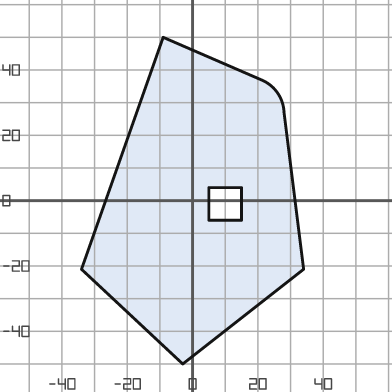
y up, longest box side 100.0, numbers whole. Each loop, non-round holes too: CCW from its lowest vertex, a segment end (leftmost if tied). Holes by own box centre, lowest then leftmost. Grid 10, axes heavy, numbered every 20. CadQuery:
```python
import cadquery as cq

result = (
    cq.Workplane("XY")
    .moveTo(-3.0, -50.0)
    .lineTo(34.0, -21.0)
    .lineTo(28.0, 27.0)
    .threePointArc((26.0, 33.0), (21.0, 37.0))
    .lineTo(-9.0, 50.0)
    .lineTo(-34.0, -21.0)
    .close()
    .moveTo(5.0, -6.0)
    .lineTo(15.0, -6.0)
    .lineTo(15.0, 4.0)
    .lineTo(5.0, 4.0)
    .close()
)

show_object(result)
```